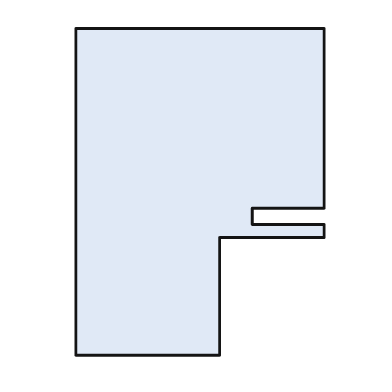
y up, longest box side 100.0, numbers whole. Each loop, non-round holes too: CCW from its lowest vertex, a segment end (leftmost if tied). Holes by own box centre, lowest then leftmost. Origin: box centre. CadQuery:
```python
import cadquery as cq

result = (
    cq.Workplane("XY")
    .moveTo(-38.0, -50.0)
    .lineTo(6.0, -50.0)
    .lineTo(6.0, -14.0)
    .lineTo(38.0, -14.0)
    .lineTo(38.0, -10.0)
    .lineTo(16.0, -10.0)
    .lineTo(16.0, -5.0)
    .lineTo(38.0, -5.0)
    .lineTo(38.0, 50.0)
    .lineTo(-38.0, 50.0)
    .close()
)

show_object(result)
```